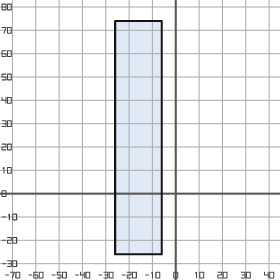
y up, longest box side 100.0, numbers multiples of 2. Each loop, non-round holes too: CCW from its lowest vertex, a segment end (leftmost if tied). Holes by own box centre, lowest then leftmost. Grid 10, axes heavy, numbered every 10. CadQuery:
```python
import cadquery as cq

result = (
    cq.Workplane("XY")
    .moveTo(-26.0, -26.0)
    .lineTo(-6.0, -26.0)
    .lineTo(-6.0, 74.0)
    .lineTo(-26.0, 74.0)
    .close()
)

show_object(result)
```